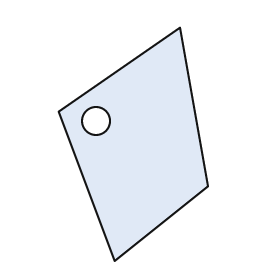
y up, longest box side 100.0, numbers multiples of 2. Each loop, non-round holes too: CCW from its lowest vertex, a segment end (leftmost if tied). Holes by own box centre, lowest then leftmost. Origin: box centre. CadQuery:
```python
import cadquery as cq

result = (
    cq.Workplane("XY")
    .moveTo(-8.0, -50.0)
    .lineTo(32.0, -18.0)
    .lineTo(20.0, 50.0)
    .lineTo(-32.0, 14.0)
    .close()
    .moveTo(-16.0, 10.0)
    .circle(6.0)
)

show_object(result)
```